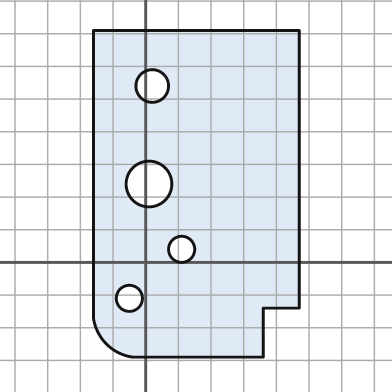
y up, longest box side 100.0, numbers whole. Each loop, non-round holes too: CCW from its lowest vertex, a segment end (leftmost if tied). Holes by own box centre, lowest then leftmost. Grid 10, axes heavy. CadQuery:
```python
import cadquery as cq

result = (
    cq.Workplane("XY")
    .moveTo(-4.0, -29.0)
    .lineTo(36.0, -29.0)
    .lineTo(36.0, -14.0)
    .lineTo(47.0, -14.0)
    .lineTo(47.0, 71.0)
    .lineTo(-16.0, 71.0)
    .lineTo(-16.0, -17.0)
    .threePointArc((-12.0, -25.0), (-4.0, -29.0))
    .close()
    .moveTo(-5.0, -11.0)
    .circle(4.0)
    .moveTo(11.0, 4.0)
    .circle(4.0)
    .moveTo(1.0, 24.0)
    .circle(7.0)
    .moveTo(2.0, 54.0)
    .circle(5.0)
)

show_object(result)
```